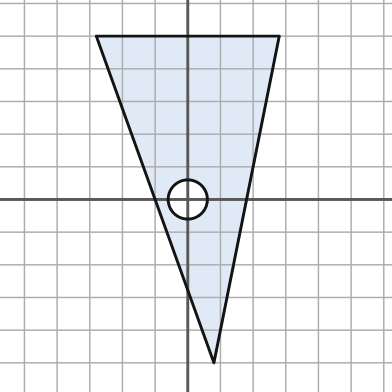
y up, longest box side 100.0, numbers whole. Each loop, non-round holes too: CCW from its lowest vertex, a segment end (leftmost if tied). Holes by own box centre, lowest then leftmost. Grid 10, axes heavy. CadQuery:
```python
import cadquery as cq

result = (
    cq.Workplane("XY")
    .moveTo(8.0, -50.0)
    .lineTo(28.0, 50.0)
    .lineTo(-28.0, 50.0)
    .close()
    .moveTo(0.0, 0.0)
    .circle(6.0)
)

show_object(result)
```